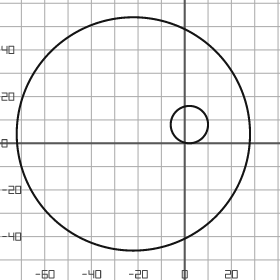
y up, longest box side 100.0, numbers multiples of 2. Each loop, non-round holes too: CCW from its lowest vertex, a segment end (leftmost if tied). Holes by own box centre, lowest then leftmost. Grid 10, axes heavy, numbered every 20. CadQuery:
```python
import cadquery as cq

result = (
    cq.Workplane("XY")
    .moveTo(-22.0, 4.0)
    .circle(50.0)
    .moveTo(2.0, 8.0)
    .circle(8.0)
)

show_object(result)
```